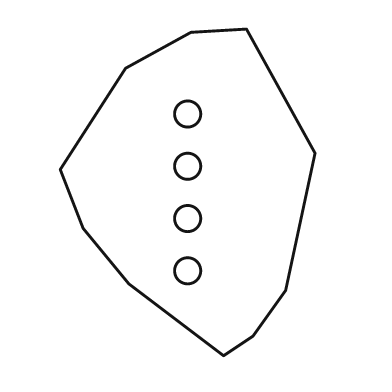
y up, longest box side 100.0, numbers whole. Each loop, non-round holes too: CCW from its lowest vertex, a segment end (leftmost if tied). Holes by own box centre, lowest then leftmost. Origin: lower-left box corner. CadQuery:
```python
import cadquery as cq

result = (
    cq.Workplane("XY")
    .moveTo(50.0, 0.0)
    .lineTo(59.0, 6.0)
    .lineTo(69.0, 20.0)
    .lineTo(78.0, 62.0)
    .lineTo(57.0, 100.0)
    .lineTo(40.0, 99.0)
    .lineTo(20.0, 88.0)
    .lineTo(0.0, 57.0)
    .lineTo(7.0, 39.0)
    .lineTo(21.0, 22.0)
    .close()
    .moveTo(39.0, 26.0)
    .circle(4.0)
    .moveTo(39.0, 42.0)
    .circle(4.0)
    .moveTo(39.0, 58.0)
    .circle(4.0)
    .moveTo(39.0, 74.0)
    .circle(4.0)
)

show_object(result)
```